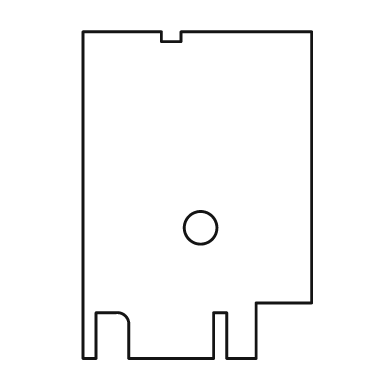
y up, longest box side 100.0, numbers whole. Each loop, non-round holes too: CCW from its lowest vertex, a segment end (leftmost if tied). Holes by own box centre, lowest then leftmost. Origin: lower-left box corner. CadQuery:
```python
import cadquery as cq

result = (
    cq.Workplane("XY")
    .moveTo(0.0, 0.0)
    .lineTo(4.0, 0.0)
    .lineTo(4.0, 14.0)
    .lineTo(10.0, 14.0)
    .threePointArc((13.0, 13.0), (14.0, 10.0))
    .lineTo(14.0, 0.0)
    .lineTo(40.0, 0.0)
    .lineTo(40.0, 14.0)
    .lineTo(44.0, 14.0)
    .lineTo(44.0, 0.0)
    .lineTo(53.0, 0.0)
    .lineTo(53.0, 17.0)
    .lineTo(70.0, 17.0)
    .lineTo(70.0, 100.0)
    .lineTo(30.0, 100.0)
    .lineTo(30.0, 97.0)
    .lineTo(24.0, 97.0)
    .lineTo(24.0, 100.0)
    .lineTo(0.0, 100.0)
    .close()
    .moveTo(36.0, 40.0)
    .circle(5.0)
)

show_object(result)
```